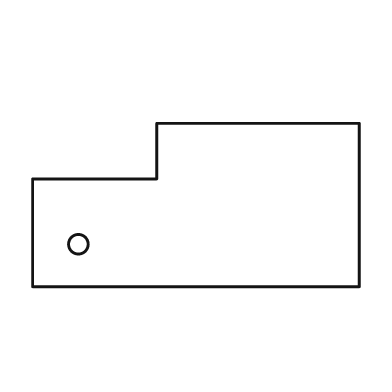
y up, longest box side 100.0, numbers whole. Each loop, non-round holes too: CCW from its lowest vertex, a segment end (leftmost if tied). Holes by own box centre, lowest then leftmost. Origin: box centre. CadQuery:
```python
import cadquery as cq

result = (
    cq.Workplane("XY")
    .moveTo(-50.0, -25.0)
    .lineTo(50.0, -25.0)
    .lineTo(50.0, 25.0)
    .lineTo(-12.0, 25.0)
    .lineTo(-12.0, 8.0)
    .lineTo(-50.0, 8.0)
    .close()
    .moveTo(-36.0, -12.0)
    .circle(3.0)
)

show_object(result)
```